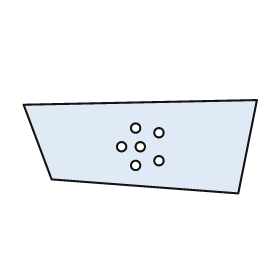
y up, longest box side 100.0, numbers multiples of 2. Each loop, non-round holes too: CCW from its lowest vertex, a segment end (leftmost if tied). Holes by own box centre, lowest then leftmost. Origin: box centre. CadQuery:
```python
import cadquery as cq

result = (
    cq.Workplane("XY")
    .moveTo(42.0, -20.0)
    .lineTo(50.0, 20.0)
    .lineTo(-50.0, 18.0)
    .lineTo(-38.0, -14.0)
    .close()
    .moveTo(-2.0, -8.0)
    .circle(2.0)
    .moveTo(8.0, -6.0)
    .circle(2.0)
    .moveTo(-8.0, 0.0)
    .circle(2.0)
    .moveTo(0.0, 0.0)
    .circle(2.0)
    .moveTo(8.0, 6.0)
    .circle(2.0)
    .moveTo(-2.0, 8.0)
    .circle(2.0)
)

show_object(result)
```